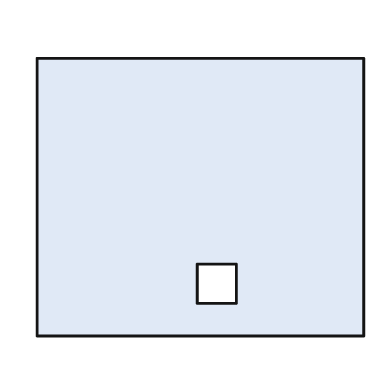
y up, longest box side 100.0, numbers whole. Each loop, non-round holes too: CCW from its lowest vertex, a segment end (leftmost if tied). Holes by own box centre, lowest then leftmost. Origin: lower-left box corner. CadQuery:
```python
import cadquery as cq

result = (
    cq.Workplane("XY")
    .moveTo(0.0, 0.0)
    .lineTo(100.0, 0.0)
    .lineTo(100.0, 85.0)
    .lineTo(0.0, 85.0)
    .close()
    .moveTo(49.0, 10.0)
    .lineTo(61.0, 10.0)
    .lineTo(61.0, 22.0)
    .lineTo(49.0, 22.0)
    .close()
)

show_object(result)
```